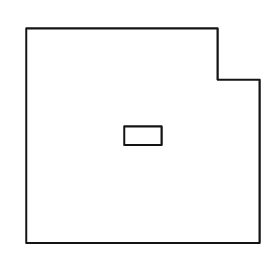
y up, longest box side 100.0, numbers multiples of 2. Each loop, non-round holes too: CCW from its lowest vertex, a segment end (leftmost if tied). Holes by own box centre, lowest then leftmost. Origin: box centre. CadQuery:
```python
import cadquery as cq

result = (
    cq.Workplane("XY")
    .moveTo(-50.0, -46.0)
    .lineTo(50.0, -46.0)
    .lineTo(50.0, 24.0)
    .lineTo(32.0, 24.0)
    .lineTo(32.0, 46.0)
    .lineTo(-50.0, 46.0)
    .close()
    .moveTo(-8.0, -4.0)
    .lineTo(8.0, -4.0)
    .lineTo(8.0, 4.0)
    .lineTo(-8.0, 4.0)
    .close()
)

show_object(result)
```